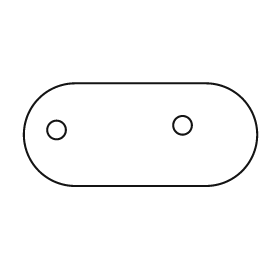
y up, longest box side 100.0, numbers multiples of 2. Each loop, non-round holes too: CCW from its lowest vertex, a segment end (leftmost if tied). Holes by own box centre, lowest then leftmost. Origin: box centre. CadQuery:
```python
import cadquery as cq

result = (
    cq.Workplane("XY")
    .moveTo(-28.0, -22.0)
    .lineTo(28.0, -22.0)
    .threePointArc((50.0, 0.0), (28.0, 22.0))
    .lineTo(-28.0, 22.0)
    .threePointArc((-50.0, 0.0), (-28.0, -22.0))
    .close()
    .moveTo(-36.0, 2.0)
    .circle(4.0)
    .moveTo(18.0, 4.0)
    .circle(4.0)
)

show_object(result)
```